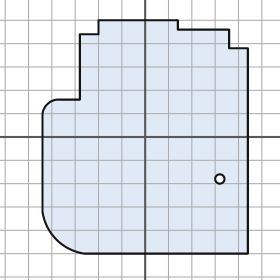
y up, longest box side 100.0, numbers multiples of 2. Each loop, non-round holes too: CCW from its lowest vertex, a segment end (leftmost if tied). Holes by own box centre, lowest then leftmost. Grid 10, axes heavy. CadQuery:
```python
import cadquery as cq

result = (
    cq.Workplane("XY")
    .moveTo(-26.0, -50.0)
    .lineTo(44.0, -50.0)
    .lineTo(44.0, 38.0)
    .lineTo(36.0, 38.0)
    .lineTo(36.0, 46.0)
    .lineTo(14.0, 46.0)
    .lineTo(14.0, 50.0)
    .lineTo(-20.0, 50.0)
    .lineTo(-20.0, 44.0)
    .lineTo(-28.0, 44.0)
    .lineTo(-28.0, 16.0)
    .lineTo(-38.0, 16.0)
    .threePointArc((-42.0, 14.0), (-44.0, 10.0))
    .lineTo(-44.0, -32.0)
    .threePointArc((-38.0, -44.0), (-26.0, -50.0))
    .close()
    .moveTo(32.0, -18.0)
    .circle(2.0)
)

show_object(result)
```